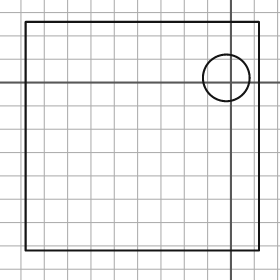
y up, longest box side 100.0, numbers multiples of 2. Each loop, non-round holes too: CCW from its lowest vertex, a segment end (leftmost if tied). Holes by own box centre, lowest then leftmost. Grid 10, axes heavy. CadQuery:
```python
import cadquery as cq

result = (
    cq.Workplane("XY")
    .moveTo(-88.0, -72.0)
    .lineTo(12.0, -72.0)
    .lineTo(12.0, 26.0)
    .lineTo(-88.0, 26.0)
    .close()
    .moveTo(-2.0, 2.0)
    .circle(10.0)
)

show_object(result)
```